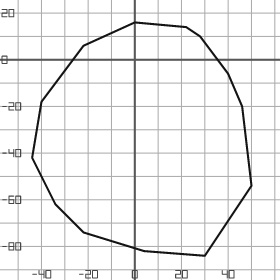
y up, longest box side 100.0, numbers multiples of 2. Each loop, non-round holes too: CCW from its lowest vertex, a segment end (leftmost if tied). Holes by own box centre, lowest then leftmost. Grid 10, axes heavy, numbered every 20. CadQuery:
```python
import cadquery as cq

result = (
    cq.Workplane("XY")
    .moveTo(30.0, -84.0)
    .lineTo(50.0, -54.0)
    .lineTo(46.0, -20.0)
    .lineTo(40.0, -6.0)
    .lineTo(28.0, 10.0)
    .lineTo(22.0, 14.0)
    .lineTo(0.0, 16.0)
    .lineTo(-22.0, 6.0)
    .lineTo(-40.0, -18.0)
    .lineTo(-44.0, -42.0)
    .lineTo(-34.0, -62.0)
    .lineTo(-22.0, -74.0)
    .lineTo(4.0, -82.0)
    .close()
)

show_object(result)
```